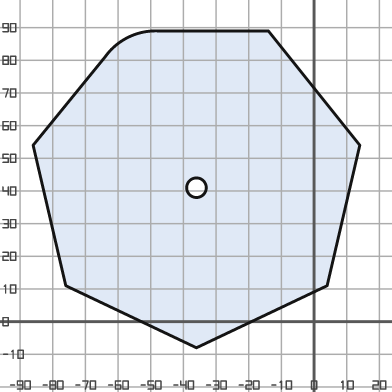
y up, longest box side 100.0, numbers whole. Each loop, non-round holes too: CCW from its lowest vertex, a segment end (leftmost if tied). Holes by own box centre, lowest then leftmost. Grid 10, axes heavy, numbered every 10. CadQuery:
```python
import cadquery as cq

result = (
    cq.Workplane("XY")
    .moveTo(-36.0, -8.0)
    .lineTo(4.0, 11.0)
    .lineTo(14.0, 54.0)
    .lineTo(-14.0, 89.0)
    .lineTo(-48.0, 89.0)
    .threePointArc((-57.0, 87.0), (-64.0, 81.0))
    .lineTo(-86.0, 54.0)
    .lineTo(-76.0, 11.0)
    .close()
    .moveTo(-36.0, 41.0)
    .circle(3.0)
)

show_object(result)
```